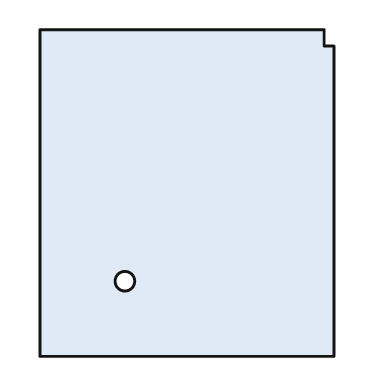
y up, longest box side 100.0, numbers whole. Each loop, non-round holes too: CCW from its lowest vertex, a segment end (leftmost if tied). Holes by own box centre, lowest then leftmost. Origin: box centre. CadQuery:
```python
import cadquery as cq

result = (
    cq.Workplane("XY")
    .moveTo(-45.0, -50.0)
    .lineTo(45.0, -50.0)
    .lineTo(45.0, 45.0)
    .lineTo(42.0, 45.0)
    .lineTo(42.0, 50.0)
    .lineTo(-45.0, 50.0)
    .close()
    .moveTo(-19.0, -27.0)
    .circle(3.0)
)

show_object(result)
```